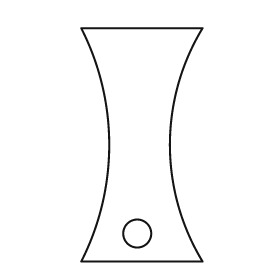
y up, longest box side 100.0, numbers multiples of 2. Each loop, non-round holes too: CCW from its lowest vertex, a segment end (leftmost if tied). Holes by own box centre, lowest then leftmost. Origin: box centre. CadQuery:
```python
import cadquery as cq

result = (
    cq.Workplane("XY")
    .moveTo(-26.0, -50.0)
    .lineTo(26.0, -50.0)
    .threePointArc((12.0, 0.0), (26.0, 50.0))
    .lineTo(-26.0, 50.0)
    .threePointArc((-14.0, 0.0), (-26.0, -50.0))
    .close()
    .moveTo(-2.0, -38.0)
    .circle(6.0)
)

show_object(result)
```